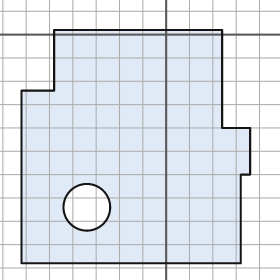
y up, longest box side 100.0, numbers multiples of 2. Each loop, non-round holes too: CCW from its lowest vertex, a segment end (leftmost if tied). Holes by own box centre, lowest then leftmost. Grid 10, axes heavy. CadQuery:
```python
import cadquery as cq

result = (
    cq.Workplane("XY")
    .moveTo(-62.0, -98.0)
    .lineTo(32.0, -98.0)
    .lineTo(32.0, -60.0)
    .lineTo(36.0, -60.0)
    .lineTo(36.0, -40.0)
    .lineTo(24.0, -40.0)
    .lineTo(24.0, 2.0)
    .lineTo(-48.0, 2.0)
    .lineTo(-48.0, -24.0)
    .lineTo(-62.0, -24.0)
    .close()
    .moveTo(-34.0, -74.0)
    .circle(10.0)
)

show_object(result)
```